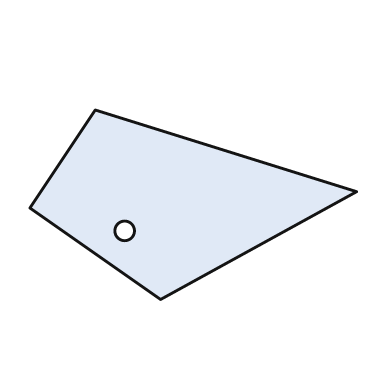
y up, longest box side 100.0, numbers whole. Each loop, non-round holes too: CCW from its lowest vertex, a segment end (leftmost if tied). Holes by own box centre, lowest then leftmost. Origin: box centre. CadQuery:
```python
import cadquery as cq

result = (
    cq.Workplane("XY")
    .moveTo(-10.0, -29.0)
    .lineTo(50.0, 4.0)
    .lineTo(-30.0, 29.0)
    .lineTo(-50.0, -1.0)
    .close()
    .moveTo(-21.0, -8.0)
    .circle(3.0)
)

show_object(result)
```